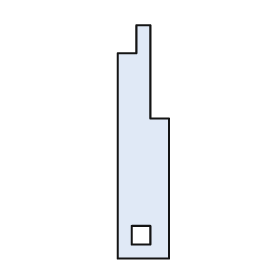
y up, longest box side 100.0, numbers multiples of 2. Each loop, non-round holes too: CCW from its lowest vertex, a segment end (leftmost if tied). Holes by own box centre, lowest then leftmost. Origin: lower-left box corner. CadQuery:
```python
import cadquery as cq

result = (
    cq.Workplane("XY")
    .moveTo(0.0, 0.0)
    .lineTo(22.0, 0.0)
    .lineTo(22.0, 60.0)
    .lineTo(14.0, 60.0)
    .lineTo(14.0, 100.0)
    .lineTo(8.0, 100.0)
    .lineTo(8.0, 88.0)
    .lineTo(0.0, 88.0)
    .close()
    .moveTo(6.0, 6.0)
    .lineTo(14.0, 6.0)
    .lineTo(14.0, 14.0)
    .lineTo(6.0, 14.0)
    .close()
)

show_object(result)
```